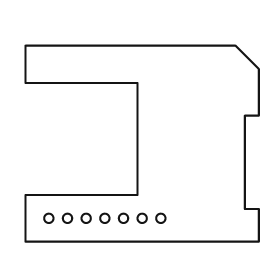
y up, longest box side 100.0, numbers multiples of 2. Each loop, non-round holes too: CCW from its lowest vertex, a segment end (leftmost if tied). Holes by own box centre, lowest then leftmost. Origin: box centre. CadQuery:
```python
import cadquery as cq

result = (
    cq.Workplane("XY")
    .moveTo(-50.0, -42.0)
    .lineTo(50.0, -42.0)
    .lineTo(50.0, -28.0)
    .lineTo(44.0, -28.0)
    .lineTo(44.0, 12.0)
    .lineTo(50.0, 12.0)
    .lineTo(50.0, 32.0)
    .lineTo(40.0, 42.0)
    .lineTo(-50.0, 42.0)
    .lineTo(-50.0, 26.0)
    .lineTo(-2.0, 26.0)
    .lineTo(-2.0, -22.0)
    .lineTo(-50.0, -22.0)
    .close()
    .moveTo(-40.0, -32.0)
    .circle(2.0)
    .moveTo(-32.0, -32.0)
    .circle(2.0)
    .moveTo(-24.0, -32.0)
    .circle(2.0)
    .moveTo(-16.0, -32.0)
    .circle(2.0)
    .moveTo(-8.0, -32.0)
    .circle(2.0)
    .moveTo(0.0, -32.0)
    .circle(2.0)
    .moveTo(8.0, -32.0)
    .circle(2.0)
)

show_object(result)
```